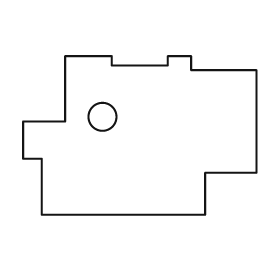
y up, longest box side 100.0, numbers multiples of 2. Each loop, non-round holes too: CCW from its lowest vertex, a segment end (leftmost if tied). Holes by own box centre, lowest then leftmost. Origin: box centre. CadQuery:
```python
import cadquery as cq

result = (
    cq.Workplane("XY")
    .moveTo(-42.0, -34.0)
    .lineTo(28.0, -34.0)
    .lineTo(28.0, -16.0)
    .lineTo(50.0, -16.0)
    .lineTo(50.0, 28.0)
    .lineTo(22.0, 28.0)
    .lineTo(22.0, 34.0)
    .lineTo(12.0, 34.0)
    .lineTo(12.0, 30.0)
    .lineTo(-12.0, 30.0)
    .lineTo(-12.0, 34.0)
    .lineTo(-32.0, 34.0)
    .lineTo(-32.0, 6.0)
    .lineTo(-50.0, 6.0)
    .lineTo(-50.0, -10.0)
    .lineTo(-42.0, -10.0)
    .close()
    .moveTo(-16.0, 8.0)
    .circle(6.0)
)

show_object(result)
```